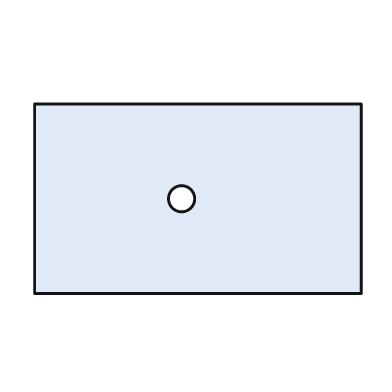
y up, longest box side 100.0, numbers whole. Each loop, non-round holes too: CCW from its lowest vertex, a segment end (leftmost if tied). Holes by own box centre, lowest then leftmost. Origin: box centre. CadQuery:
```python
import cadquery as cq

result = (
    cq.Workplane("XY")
    .moveTo(-50.0, -29.0)
    .lineTo(50.0, -29.0)
    .lineTo(50.0, 29.0)
    .lineTo(-50.0, 29.0)
    .close()
    .moveTo(-5.0, 0.0)
    .circle(4.0)
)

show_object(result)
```